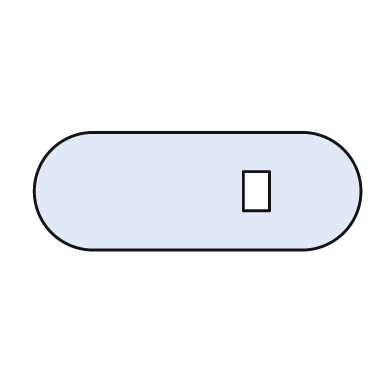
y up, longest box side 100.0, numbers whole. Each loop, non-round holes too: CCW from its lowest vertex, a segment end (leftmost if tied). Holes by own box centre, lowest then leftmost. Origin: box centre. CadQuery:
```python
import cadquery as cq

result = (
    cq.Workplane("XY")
    .moveTo(-32.0, -18.0)
    .lineTo(32.0, -18.0)
    .threePointArc((50.0, 0.0), (32.0, 18.0))
    .lineTo(-32.0, 18.0)
    .threePointArc((-50.0, 0.0), (-32.0, -18.0))
    .close()
    .moveTo(14.0, -6.0)
    .lineTo(22.0, -6.0)
    .lineTo(22.0, 6.0)
    .lineTo(14.0, 6.0)
    .close()
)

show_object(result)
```